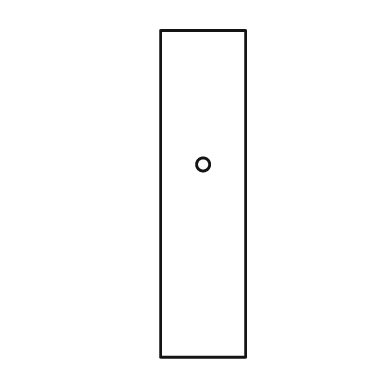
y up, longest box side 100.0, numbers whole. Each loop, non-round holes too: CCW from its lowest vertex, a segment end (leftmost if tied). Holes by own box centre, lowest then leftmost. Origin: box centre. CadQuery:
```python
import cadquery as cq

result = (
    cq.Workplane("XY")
    .moveTo(-13.0, -50.0)
    .lineTo(13.0, -50.0)
    .lineTo(13.0, 50.0)
    .lineTo(-13.0, 50.0)
    .close()
    .moveTo(0.0, 9.0)
    .circle(2.0)
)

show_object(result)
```